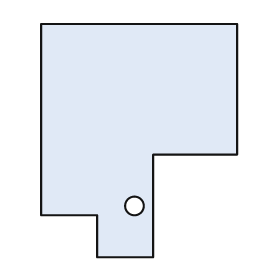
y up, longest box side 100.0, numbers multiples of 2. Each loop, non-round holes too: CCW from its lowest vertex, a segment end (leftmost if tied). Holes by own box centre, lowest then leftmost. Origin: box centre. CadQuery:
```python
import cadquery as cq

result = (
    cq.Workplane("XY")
    .moveTo(-18.0, -50.0)
    .lineTo(6.0, -50.0)
    .lineTo(6.0, -6.0)
    .lineTo(42.0, -6.0)
    .lineTo(42.0, 50.0)
    .lineTo(-42.0, 50.0)
    .lineTo(-42.0, -32.0)
    .lineTo(-18.0, -32.0)
    .close()
    .moveTo(-2.0, -28.0)
    .circle(4.0)
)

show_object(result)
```